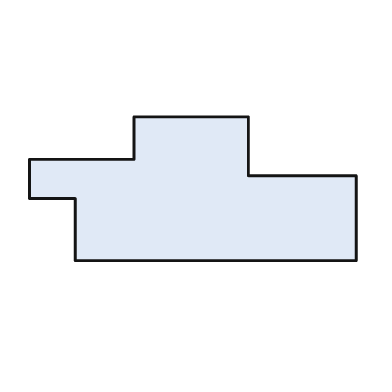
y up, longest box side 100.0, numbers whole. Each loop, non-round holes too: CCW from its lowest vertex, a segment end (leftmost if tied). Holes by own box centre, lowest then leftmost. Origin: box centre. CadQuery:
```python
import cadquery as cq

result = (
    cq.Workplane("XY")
    .moveTo(-36.0, -22.0)
    .lineTo(50.0, -22.0)
    .lineTo(50.0, 4.0)
    .lineTo(17.0, 4.0)
    .lineTo(17.0, 22.0)
    .lineTo(-18.0, 22.0)
    .lineTo(-18.0, 9.0)
    .lineTo(-50.0, 9.0)
    .lineTo(-50.0, -3.0)
    .lineTo(-36.0, -3.0)
    .close()
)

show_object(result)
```